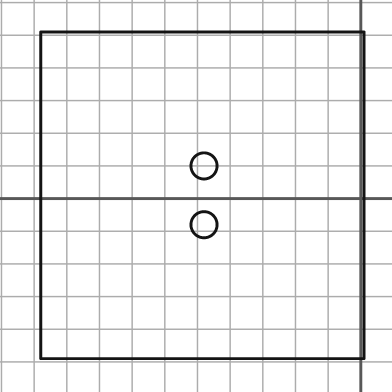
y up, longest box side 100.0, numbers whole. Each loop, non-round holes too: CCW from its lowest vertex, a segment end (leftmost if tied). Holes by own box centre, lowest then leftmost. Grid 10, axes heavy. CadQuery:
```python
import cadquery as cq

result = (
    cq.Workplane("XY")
    .moveTo(-98.0, -49.0)
    .lineTo(1.0, -49.0)
    .lineTo(1.0, 51.0)
    .lineTo(-98.0, 51.0)
    .close()
    .moveTo(-48.0, -8.0)
    .circle(4.0)
    .moveTo(-48.0, 10.0)
    .circle(4.0)
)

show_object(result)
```